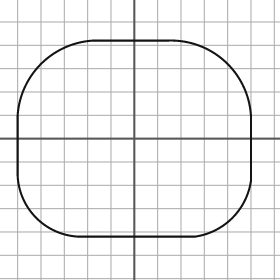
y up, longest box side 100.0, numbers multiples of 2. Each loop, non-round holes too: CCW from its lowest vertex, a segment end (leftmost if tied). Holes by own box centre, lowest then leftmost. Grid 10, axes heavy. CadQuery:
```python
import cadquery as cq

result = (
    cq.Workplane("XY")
    .moveTo(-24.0, -42.0)
    .lineTo(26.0, -42.0)
    .threePointArc((42.0, -34.0), (50.0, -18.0))
    .lineTo(50.0, 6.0)
    .threePointArc((40.0, 32.0), (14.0, 42.0))
    .lineTo(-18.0, 42.0)
    .threePointArc((-40.0, 32.0), (-50.0, 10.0))
    .lineTo(-50.0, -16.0)
    .threePointArc((-42.0, -34.0), (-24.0, -42.0))
    .close()
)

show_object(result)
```